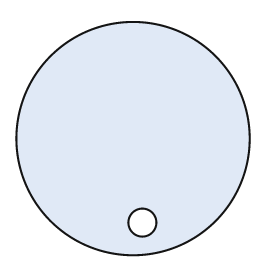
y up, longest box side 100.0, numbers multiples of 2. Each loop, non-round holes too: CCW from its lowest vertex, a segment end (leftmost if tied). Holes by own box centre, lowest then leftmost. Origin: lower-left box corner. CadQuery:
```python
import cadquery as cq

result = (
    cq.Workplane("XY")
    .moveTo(50.0, 50.0)
    .circle(50.0)
    .moveTo(54.0, 14.0)
    .circle(6.0)
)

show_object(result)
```